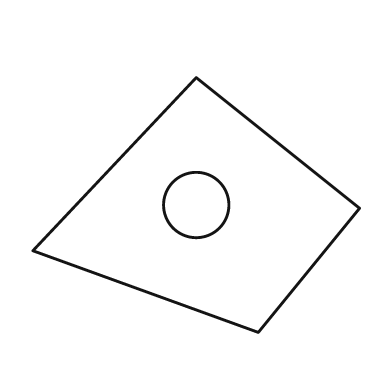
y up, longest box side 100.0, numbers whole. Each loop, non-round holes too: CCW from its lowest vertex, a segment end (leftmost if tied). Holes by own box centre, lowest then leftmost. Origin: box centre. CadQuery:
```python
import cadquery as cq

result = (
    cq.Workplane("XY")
    .moveTo(19.0, -39.0)
    .lineTo(50.0, -1.0)
    .lineTo(0.0, 39.0)
    .lineTo(-50.0, -14.0)
    .close()
    .moveTo(0.0, 0.0)
    .circle(10.0)
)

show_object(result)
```